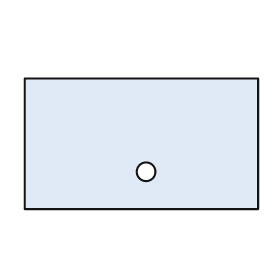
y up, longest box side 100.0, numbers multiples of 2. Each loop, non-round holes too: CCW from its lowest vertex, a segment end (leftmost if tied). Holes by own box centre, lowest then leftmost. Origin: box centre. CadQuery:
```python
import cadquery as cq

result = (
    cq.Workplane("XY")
    .moveTo(-50.0, -28.0)
    .lineTo(50.0, -28.0)
    .lineTo(50.0, 28.0)
    .lineTo(-50.0, 28.0)
    .close()
    .moveTo(2.0, -12.0)
    .circle(4.0)
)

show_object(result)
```